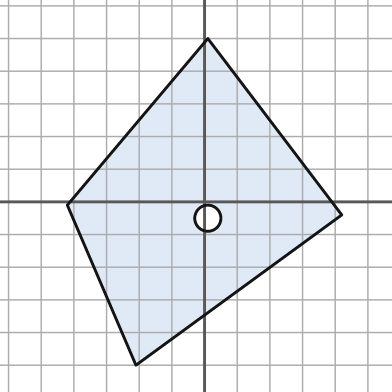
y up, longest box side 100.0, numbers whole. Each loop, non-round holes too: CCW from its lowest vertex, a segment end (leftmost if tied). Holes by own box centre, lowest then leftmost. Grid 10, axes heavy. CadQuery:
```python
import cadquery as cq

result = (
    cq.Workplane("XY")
    .moveTo(-21.0, -50.0)
    .lineTo(42.0, -4.0)
    .lineTo(1.0, 50.0)
    .lineTo(-42.0, -1.0)
    .close()
    .moveTo(1.0, -5.0)
    .circle(4.0)
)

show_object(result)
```